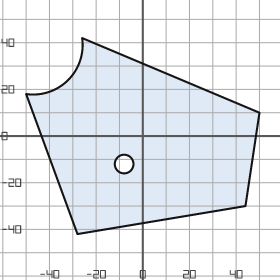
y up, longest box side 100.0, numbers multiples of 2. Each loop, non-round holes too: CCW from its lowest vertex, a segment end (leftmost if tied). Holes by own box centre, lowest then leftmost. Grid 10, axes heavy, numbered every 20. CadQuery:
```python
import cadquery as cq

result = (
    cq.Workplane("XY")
    .moveTo(-28.0, -42.0)
    .lineTo(44.0, -30.0)
    .lineTo(50.0, 10.0)
    .lineTo(-26.0, 42.0)
    .threePointArc((-32.0, 24.0), (-50.0, 18.0))
    .close()
    .moveTo(-8.0, -12.0)
    .circle(4.0)
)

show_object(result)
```